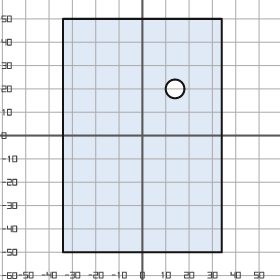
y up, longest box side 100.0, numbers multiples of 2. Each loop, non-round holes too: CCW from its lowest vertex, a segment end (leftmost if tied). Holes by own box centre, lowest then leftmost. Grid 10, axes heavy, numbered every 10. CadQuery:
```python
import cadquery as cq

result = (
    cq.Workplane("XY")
    .moveTo(-34.0, -50.0)
    .lineTo(34.0, -50.0)
    .lineTo(34.0, 50.0)
    .lineTo(-34.0, 50.0)
    .close()
    .moveTo(14.0, 20.0)
    .circle(4.0)
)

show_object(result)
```